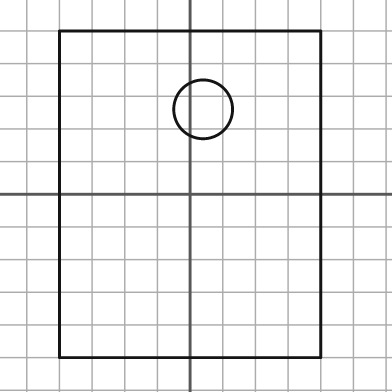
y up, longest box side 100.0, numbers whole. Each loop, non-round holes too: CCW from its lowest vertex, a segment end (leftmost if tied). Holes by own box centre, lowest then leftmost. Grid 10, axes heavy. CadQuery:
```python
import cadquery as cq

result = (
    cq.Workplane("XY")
    .moveTo(-40.0, -50.0)
    .lineTo(40.0, -50.0)
    .lineTo(40.0, 50.0)
    .lineTo(-40.0, 50.0)
    .close()
    .moveTo(4.0, 26.0)
    .circle(9.0)
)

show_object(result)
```